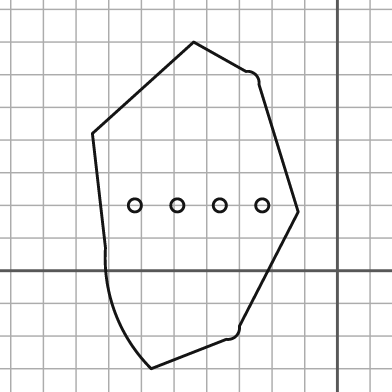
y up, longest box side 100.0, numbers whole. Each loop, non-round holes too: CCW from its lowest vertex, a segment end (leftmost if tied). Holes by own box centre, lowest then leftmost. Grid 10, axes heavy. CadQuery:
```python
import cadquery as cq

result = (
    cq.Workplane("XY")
    .moveTo(-57.0, -30.0)
    .lineTo(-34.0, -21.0)
    .threePointArc((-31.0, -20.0), (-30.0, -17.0))
    .lineTo(-12.0, 18.0)
    .lineTo(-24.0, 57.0)
    .threePointArc((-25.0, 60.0), (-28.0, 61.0))
    .lineTo(-44.0, 70.0)
    .lineTo(-75.0, 42.0)
    .lineTo(-71.0, 7.0)
    .threePointArc((-68.0, -13.0), (-57.0, -30.0))
    .close()
    .moveTo(-62.0, 20.0)
    .circle(2.0)
    .moveTo(-49.0, 20.0)
    .circle(2.0)
    .moveTo(-36.0, 20.0)
    .circle(2.0)
    .moveTo(-23.0, 20.0)
    .circle(2.0)
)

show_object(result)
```